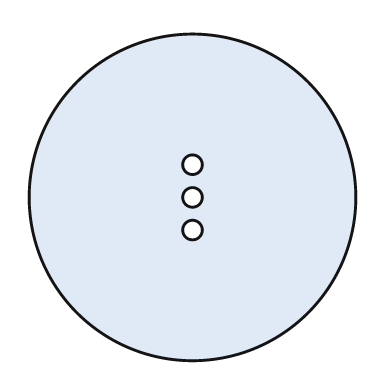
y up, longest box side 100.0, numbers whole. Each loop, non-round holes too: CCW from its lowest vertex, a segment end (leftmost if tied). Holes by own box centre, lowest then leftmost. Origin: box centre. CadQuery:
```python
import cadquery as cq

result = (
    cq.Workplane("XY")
    .moveTo(0.0, 0.0)
    .circle(50.0)
    .moveTo(0.0, -10.0)
    .circle(3.0)
    .moveTo(0.0, 0.0)
    .circle(3.0)
    .moveTo(0.0, 10.0)
    .circle(3.0)
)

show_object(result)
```